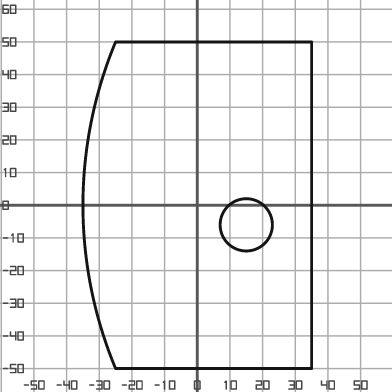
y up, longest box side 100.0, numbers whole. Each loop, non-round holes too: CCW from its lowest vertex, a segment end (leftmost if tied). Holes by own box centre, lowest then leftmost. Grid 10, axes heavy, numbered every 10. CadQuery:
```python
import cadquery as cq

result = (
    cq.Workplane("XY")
    .moveTo(-25.0, -50.0)
    .lineTo(35.0, -50.0)
    .lineTo(35.0, 50.0)
    .lineTo(-25.0, 50.0)
    .threePointArc((-35.0, 0.0), (-25.0, -50.0))
    .close()
    .moveTo(15.0, -6.0)
    .circle(8.0)
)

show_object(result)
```